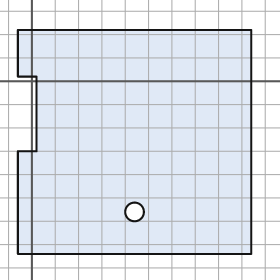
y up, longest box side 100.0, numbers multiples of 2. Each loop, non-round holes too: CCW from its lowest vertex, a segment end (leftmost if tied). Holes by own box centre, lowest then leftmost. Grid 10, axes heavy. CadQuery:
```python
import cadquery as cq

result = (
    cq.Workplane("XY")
    .moveTo(-6.0, -74.0)
    .lineTo(94.0, -74.0)
    .lineTo(94.0, 22.0)
    .lineTo(-6.0, 22.0)
    .lineTo(-6.0, 2.0)
    .lineTo(2.0, 2.0)
    .lineTo(2.0, -30.0)
    .lineTo(-6.0, -30.0)
    .close()
    .moveTo(44.0, -56.0)
    .circle(4.0)
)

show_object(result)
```